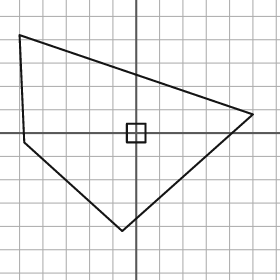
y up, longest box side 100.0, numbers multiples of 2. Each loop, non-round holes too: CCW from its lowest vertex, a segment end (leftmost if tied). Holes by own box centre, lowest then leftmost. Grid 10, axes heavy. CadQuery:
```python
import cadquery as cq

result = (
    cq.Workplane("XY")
    .moveTo(-6.0, -42.0)
    .lineTo(50.0, 8.0)
    .lineTo(-50.0, 42.0)
    .lineTo(-48.0, -4.0)
    .close()
    .moveTo(-4.0, -4.0)
    .lineTo(4.0, -4.0)
    .lineTo(4.0, 4.0)
    .lineTo(-4.0, 4.0)
    .close()
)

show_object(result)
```